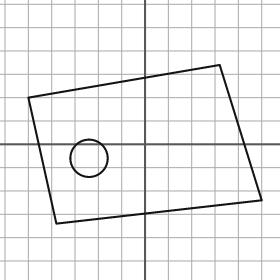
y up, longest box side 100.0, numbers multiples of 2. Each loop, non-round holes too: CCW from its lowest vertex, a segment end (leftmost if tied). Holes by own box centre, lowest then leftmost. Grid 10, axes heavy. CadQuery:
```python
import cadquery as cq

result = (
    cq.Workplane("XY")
    .moveTo(-38.0, -34.0)
    .lineTo(50.0, -24.0)
    .lineTo(32.0, 34.0)
    .lineTo(-50.0, 20.0)
    .close()
    .moveTo(-24.0, -6.0)
    .circle(8.0)
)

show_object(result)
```